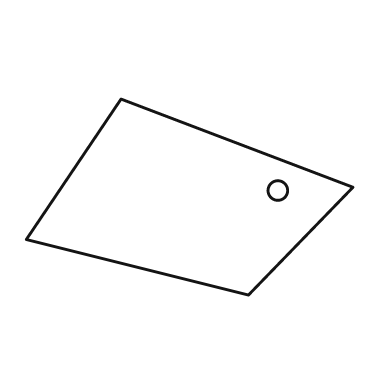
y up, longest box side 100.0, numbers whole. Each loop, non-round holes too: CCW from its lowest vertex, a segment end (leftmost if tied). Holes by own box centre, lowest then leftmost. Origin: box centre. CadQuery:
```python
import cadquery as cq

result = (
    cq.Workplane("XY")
    .moveTo(18.0, -30.0)
    .lineTo(50.0, 3.0)
    .lineTo(-21.0, 30.0)
    .lineTo(-50.0, -13.0)
    .close()
    .moveTo(27.0, 2.0)
    .circle(3.0)
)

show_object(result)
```